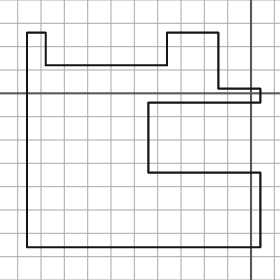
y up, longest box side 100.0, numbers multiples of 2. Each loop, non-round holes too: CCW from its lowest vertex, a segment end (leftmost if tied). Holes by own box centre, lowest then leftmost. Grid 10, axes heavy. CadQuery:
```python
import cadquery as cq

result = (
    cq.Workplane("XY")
    .moveTo(-96.0, -66.0)
    .lineTo(4.0, -66.0)
    .lineTo(4.0, -34.0)
    .lineTo(-44.0, -34.0)
    .lineTo(-44.0, -4.0)
    .lineTo(4.0, -4.0)
    .lineTo(4.0, 2.0)
    .lineTo(-14.0, 2.0)
    .lineTo(-14.0, 26.0)
    .lineTo(-36.0, 26.0)
    .lineTo(-36.0, 12.0)
    .lineTo(-88.0, 12.0)
    .lineTo(-88.0, 26.0)
    .lineTo(-96.0, 26.0)
    .close()
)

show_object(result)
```